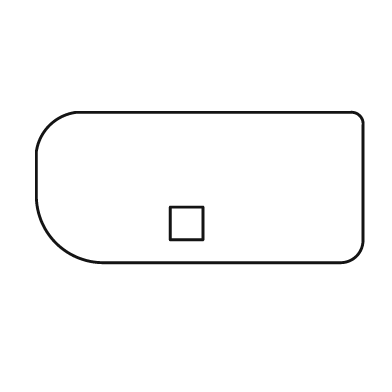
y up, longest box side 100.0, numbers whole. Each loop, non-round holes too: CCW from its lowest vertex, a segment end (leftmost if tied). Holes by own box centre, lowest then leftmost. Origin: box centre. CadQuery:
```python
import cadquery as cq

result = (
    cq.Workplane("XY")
    .moveTo(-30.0, -23.0)
    .lineTo(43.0, -23.0)
    .threePointArc((48.0, -21.0), (50.0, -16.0))
    .lineTo(50.0, 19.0)
    .threePointArc((49.0, 22.0), (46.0, 23.0))
    .lineTo(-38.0, 23.0)
    .threePointArc((-46.0, 19.0), (-50.0, 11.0))
    .lineTo(-50.0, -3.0)
    .threePointArc((-44.0, -17.0), (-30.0, -23.0))
    .close()
    .moveTo(-9.0, -16.0)
    .lineTo(1.0, -16.0)
    .lineTo(1.0, -6.0)
    .lineTo(-9.0, -6.0)
    .close()
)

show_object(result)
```